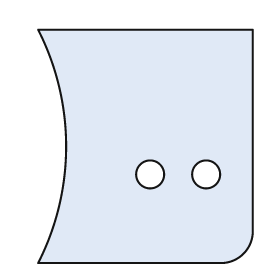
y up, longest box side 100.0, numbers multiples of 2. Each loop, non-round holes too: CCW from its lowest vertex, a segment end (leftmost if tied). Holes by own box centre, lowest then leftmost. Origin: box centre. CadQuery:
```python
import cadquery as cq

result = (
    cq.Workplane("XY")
    .moveTo(-46.0, -50.0)
    .lineTo(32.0, -50.0)
    .threePointArc((42.0, -46.0), (46.0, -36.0))
    .lineTo(46.0, 50.0)
    .lineTo(-46.0, 50.0)
    .threePointArc((-34.0, 0.0), (-46.0, -50.0))
    .close()
    .moveTo(2.0, -12.0)
    .circle(6.0)
    .moveTo(26.0, -12.0)
    .circle(6.0)
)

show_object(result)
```